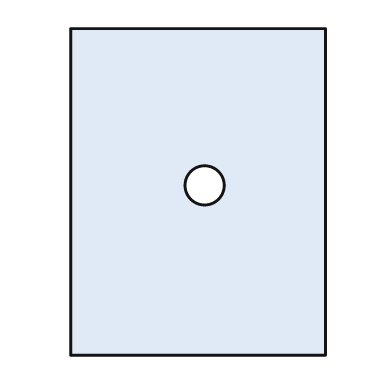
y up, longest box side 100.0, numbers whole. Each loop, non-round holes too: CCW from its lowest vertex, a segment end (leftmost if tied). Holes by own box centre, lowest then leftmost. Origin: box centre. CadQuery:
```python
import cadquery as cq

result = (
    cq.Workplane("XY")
    .moveTo(-39.0, -50.0)
    .lineTo(39.0, -50.0)
    .lineTo(39.0, 50.0)
    .lineTo(-39.0, 50.0)
    .close()
    .moveTo(2.0, 2.0)
    .circle(6.0)
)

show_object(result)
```